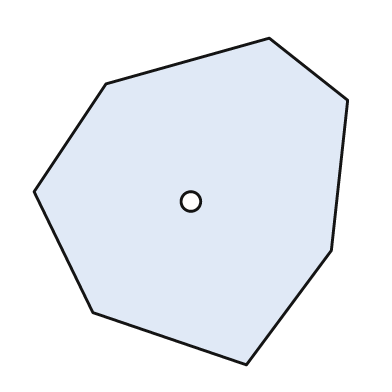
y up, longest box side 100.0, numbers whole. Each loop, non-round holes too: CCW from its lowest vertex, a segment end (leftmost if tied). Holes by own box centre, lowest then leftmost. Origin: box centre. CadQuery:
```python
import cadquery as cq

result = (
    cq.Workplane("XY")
    .moveTo(17.0, -50.0)
    .lineTo(43.0, -15.0)
    .lineTo(48.0, 31.0)
    .lineTo(24.0, 50.0)
    .lineTo(-26.0, 36.0)
    .lineTo(-48.0, 3.0)
    .lineTo(-30.0, -34.0)
    .close()
    .moveTo(0.0, 0.0)
    .circle(3.0)
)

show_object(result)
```